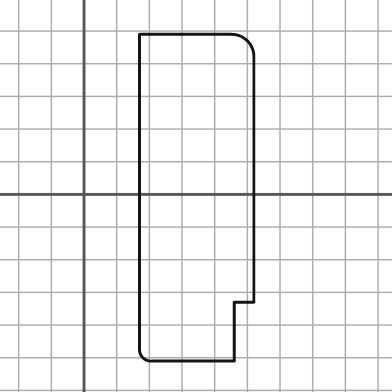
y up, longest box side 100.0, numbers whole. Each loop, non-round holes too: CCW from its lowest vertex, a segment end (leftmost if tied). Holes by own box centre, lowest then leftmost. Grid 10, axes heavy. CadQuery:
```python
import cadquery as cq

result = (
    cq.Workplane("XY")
    .moveTo(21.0, -51.0)
    .lineTo(46.0, -51.0)
    .lineTo(46.0, -33.0)
    .lineTo(52.0, -33.0)
    .lineTo(52.0, 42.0)
    .threePointArc((50.0, 47.0), (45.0, 49.0))
    .lineTo(17.0, 49.0)
    .lineTo(17.0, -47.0)
    .threePointArc((18.0, -50.0), (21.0, -51.0))
    .close()
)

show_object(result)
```